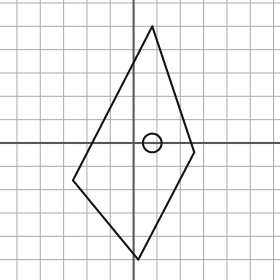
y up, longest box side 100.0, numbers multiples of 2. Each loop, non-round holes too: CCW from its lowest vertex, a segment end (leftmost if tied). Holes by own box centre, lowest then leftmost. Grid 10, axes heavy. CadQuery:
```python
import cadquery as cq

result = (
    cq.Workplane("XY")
    .moveTo(2.0, -50.0)
    .lineTo(26.0, -4.0)
    .lineTo(8.0, 50.0)
    .lineTo(-26.0, -16.0)
    .close()
    .moveTo(8.0, 0.0)
    .circle(4.0)
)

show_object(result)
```